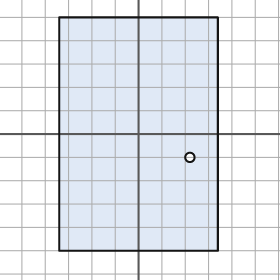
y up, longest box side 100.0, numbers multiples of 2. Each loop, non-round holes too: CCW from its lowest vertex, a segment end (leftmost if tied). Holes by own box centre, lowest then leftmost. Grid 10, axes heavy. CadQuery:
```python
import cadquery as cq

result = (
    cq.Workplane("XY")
    .moveTo(-34.0, -50.0)
    .lineTo(34.0, -50.0)
    .lineTo(34.0, 50.0)
    .lineTo(-34.0, 50.0)
    .close()
    .moveTo(22.0, -10.0)
    .circle(2.0)
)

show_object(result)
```